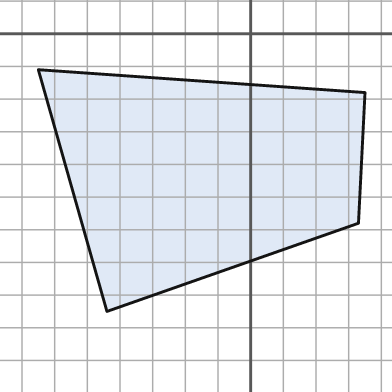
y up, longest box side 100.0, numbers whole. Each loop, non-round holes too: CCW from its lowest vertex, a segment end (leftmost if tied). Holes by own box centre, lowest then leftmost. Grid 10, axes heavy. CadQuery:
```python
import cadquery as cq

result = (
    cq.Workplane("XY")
    .moveTo(-44.0, -85.0)
    .lineTo(33.0, -58.0)
    .lineTo(35.0, -18.0)
    .lineTo(-65.0, -11.0)
    .close()
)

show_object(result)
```